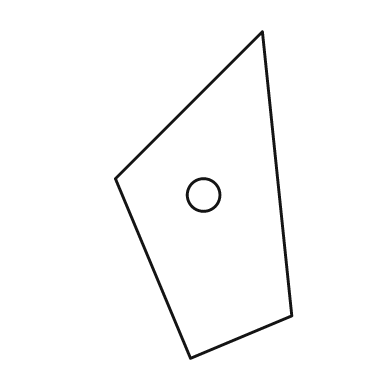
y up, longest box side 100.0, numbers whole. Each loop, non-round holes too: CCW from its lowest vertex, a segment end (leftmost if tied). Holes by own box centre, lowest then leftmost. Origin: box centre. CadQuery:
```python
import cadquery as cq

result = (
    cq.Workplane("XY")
    .moveTo(-4.0, -50.0)
    .lineTo(27.0, -37.0)
    .lineTo(18.0, 50.0)
    .lineTo(-27.0, 5.0)
    .close()
    .moveTo(0.0, 0.0)
    .circle(5.0)
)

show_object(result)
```